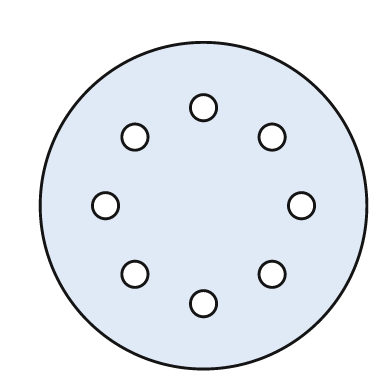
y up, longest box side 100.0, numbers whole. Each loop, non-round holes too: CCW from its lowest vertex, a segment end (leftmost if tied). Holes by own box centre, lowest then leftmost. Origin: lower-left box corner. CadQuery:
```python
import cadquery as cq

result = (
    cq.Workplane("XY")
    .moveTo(50.0, 50.0)
    .circle(50.0)
    .moveTo(50.0, 20.0)
    .circle(4.0)
    .moveTo(29.0, 29.0)
    .circle(4.0)
    .moveTo(71.0, 29.0)
    .circle(4.0)
    .moveTo(20.0, 50.0)
    .circle(4.0)
    .moveTo(80.0, 50.0)
    .circle(4.0)
    .moveTo(29.0, 71.0)
    .circle(4.0)
    .moveTo(71.0, 71.0)
    .circle(4.0)
    .moveTo(50.0, 80.0)
    .circle(4.0)
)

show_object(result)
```